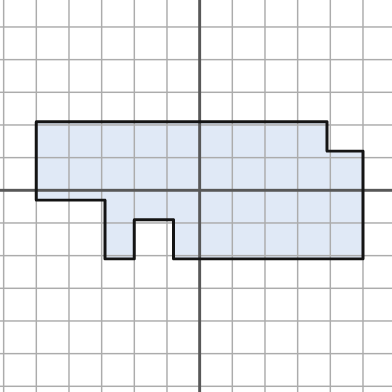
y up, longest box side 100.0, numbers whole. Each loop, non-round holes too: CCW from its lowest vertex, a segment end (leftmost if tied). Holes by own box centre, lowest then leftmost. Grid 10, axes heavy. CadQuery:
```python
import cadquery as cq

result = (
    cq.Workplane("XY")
    .moveTo(-29.0, -21.0)
    .lineTo(-20.0, -21.0)
    .lineTo(-20.0, -9.0)
    .lineTo(-8.0, -9.0)
    .lineTo(-8.0, -21.0)
    .lineTo(50.0, -21.0)
    .lineTo(50.0, 12.0)
    .lineTo(39.0, 12.0)
    .lineTo(39.0, 21.0)
    .lineTo(-50.0, 21.0)
    .lineTo(-50.0, -3.0)
    .lineTo(-29.0, -3.0)
    .close()
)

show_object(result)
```